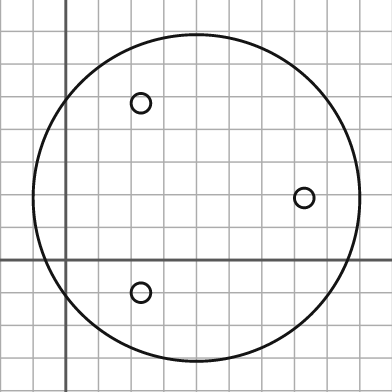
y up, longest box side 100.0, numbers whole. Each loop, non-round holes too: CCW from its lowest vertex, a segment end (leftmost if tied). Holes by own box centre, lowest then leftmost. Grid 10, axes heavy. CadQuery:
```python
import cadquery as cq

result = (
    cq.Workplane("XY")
    .moveTo(40.0, 19.0)
    .circle(50.0)
    .moveTo(23.0, -10.0)
    .circle(3.0)
    .moveTo(73.0, 19.0)
    .circle(3.0)
    .moveTo(23.0, 48.0)
    .circle(3.0)
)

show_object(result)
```